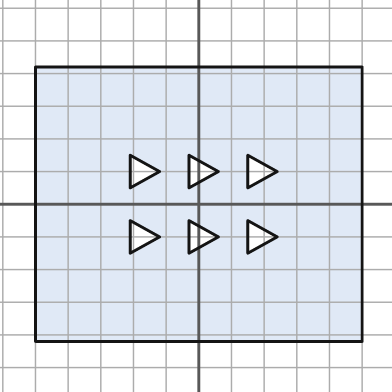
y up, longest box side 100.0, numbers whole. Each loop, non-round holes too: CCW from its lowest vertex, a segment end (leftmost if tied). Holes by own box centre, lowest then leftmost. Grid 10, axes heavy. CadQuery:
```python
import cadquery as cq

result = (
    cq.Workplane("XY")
    .moveTo(-50.0, -42.0)
    .lineTo(50.0, -42.0)
    .lineTo(50.0, 42.0)
    .lineTo(-50.0, 42.0)
    .close()
    .moveTo(-21.0, -15.0)
    .lineTo(-12.0, -10.0)
    .lineTo(-21.0, -5.0)
    .close()
    .moveTo(-3.0, -15.0)
    .lineTo(6.0, -10.0)
    .lineTo(-3.0, -5.0)
    .close()
    .moveTo(15.0, -15.0)
    .lineTo(24.0, -10.0)
    .lineTo(15.0, -5.0)
    .close()
    .moveTo(-21.0, 5.0)
    .lineTo(-12.0, 10.0)
    .lineTo(-21.0, 15.0)
    .close()
    .moveTo(-3.0, 5.0)
    .lineTo(6.0, 10.0)
    .lineTo(-3.0, 15.0)
    .close()
    .moveTo(15.0, 5.0)
    .lineTo(24.0, 10.0)
    .lineTo(15.0, 15.0)
    .close()
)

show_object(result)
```